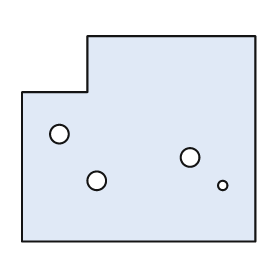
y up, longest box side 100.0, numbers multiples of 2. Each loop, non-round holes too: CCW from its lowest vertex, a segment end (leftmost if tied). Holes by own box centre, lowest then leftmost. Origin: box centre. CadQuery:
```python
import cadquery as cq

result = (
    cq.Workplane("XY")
    .moveTo(-50.0, -44.0)
    .lineTo(50.0, -44.0)
    .lineTo(50.0, 44.0)
    .lineTo(-22.0, 44.0)
    .lineTo(-22.0, 20.0)
    .lineTo(-50.0, 20.0)
    .close()
    .moveTo(36.0, -20.0)
    .circle(2.0)
    .moveTo(-18.0, -18.0)
    .circle(4.0)
    .moveTo(22.0, -8.0)
    .circle(4.0)
    .moveTo(-34.0, 2.0)
    .circle(4.0)
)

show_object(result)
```